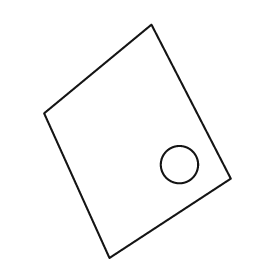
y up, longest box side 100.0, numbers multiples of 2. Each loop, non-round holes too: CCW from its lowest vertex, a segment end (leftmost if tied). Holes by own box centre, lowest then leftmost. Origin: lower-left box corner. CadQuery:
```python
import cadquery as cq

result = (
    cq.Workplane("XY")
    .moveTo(28.0, 0.0)
    .lineTo(80.0, 34.0)
    .lineTo(46.0, 100.0)
    .lineTo(0.0, 62.0)
    .close()
    .moveTo(58.0, 40.0)
    .circle(8.0)
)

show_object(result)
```